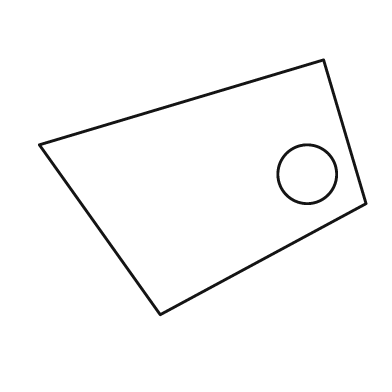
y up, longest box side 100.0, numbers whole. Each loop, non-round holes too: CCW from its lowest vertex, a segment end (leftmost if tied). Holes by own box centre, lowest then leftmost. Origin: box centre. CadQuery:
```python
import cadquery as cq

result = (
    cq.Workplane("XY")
    .moveTo(-13.0, -39.0)
    .lineTo(50.0, -5.0)
    .lineTo(37.0, 39.0)
    .lineTo(-50.0, 13.0)
    .close()
    .moveTo(32.0, 4.0)
    .circle(9.0)
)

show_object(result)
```